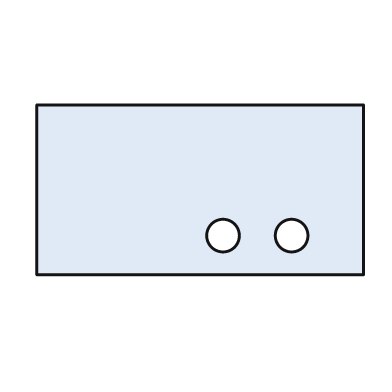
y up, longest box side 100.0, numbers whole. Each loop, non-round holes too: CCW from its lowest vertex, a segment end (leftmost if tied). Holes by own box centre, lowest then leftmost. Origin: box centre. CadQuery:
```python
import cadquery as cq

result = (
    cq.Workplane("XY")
    .moveTo(-50.0, -26.0)
    .lineTo(50.0, -26.0)
    .lineTo(50.0, 26.0)
    .lineTo(-50.0, 26.0)
    .close()
    .moveTo(7.0, -14.0)
    .circle(5.0)
    .moveTo(28.0, -14.0)
    .circle(5.0)
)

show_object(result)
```